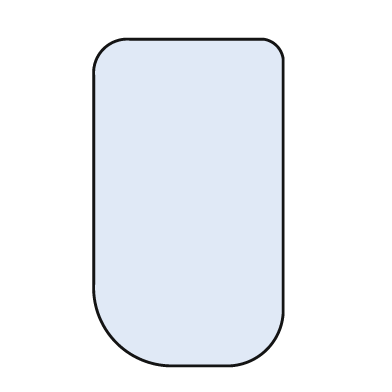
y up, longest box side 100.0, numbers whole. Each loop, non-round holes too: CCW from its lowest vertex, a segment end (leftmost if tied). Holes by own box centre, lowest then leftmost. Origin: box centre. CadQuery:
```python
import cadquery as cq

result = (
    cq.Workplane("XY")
    .moveTo(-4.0, -50.0)
    .lineTo(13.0, -50.0)
    .threePointArc((24.0, -45.0), (29.0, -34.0))
    .lineTo(29.0, 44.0)
    .threePointArc((27.0, 48.0), (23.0, 50.0))
    .lineTo(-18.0, 50.0)
    .threePointArc((-26.0, 47.0), (-29.0, 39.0))
    .lineTo(-29.0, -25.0)
    .threePointArc((-22.0, -43.0), (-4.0, -50.0))
    .close()
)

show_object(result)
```